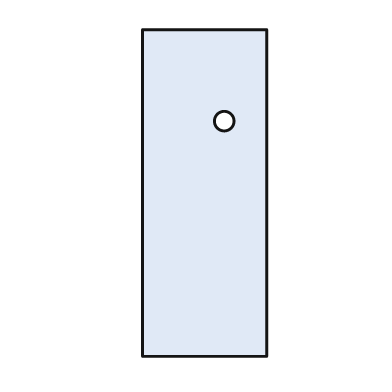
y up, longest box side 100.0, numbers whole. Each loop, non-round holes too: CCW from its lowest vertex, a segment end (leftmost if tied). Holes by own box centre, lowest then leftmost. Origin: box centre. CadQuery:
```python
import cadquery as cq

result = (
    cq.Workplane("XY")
    .moveTo(-19.0, -50.0)
    .lineTo(19.0, -50.0)
    .lineTo(19.0, 50.0)
    .lineTo(-19.0, 50.0)
    .close()
    .moveTo(6.0, 22.0)
    .circle(3.0)
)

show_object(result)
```